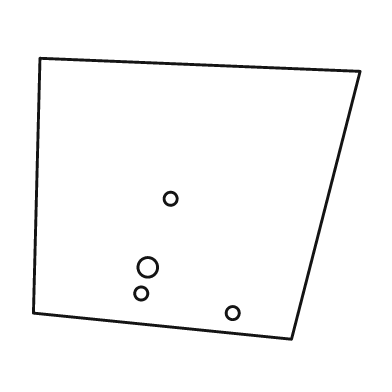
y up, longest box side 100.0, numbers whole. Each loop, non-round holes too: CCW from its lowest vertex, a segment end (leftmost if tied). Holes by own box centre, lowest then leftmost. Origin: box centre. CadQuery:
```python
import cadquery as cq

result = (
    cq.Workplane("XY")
    .moveTo(29.0, -43.0)
    .lineTo(50.0, 39.0)
    .lineTo(-48.0, 43.0)
    .lineTo(-50.0, -35.0)
    .close()
    .moveTo(11.0, -35.0)
    .circle(2.0)
    .moveTo(-17.0, -29.0)
    .circle(2.0)
    .moveTo(-15.0, -21.0)
    .circle(3.0)
    .moveTo(-8.0, 0.0)
    .circle(2.0)
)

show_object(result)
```